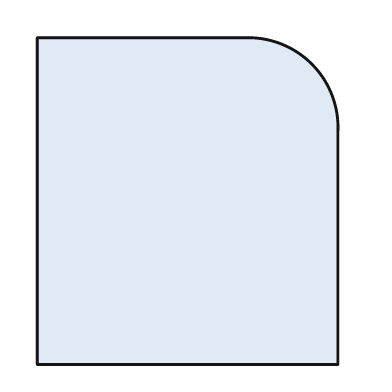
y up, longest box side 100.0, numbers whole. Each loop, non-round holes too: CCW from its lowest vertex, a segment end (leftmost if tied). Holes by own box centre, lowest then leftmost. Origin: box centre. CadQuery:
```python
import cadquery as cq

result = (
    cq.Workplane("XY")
    .moveTo(-46.0, -50.0)
    .lineTo(46.0, -50.0)
    .lineTo(46.0, 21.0)
    .threePointArc((38.0, 42.0), (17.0, 50.0))
    .lineTo(-46.0, 50.0)
    .close()
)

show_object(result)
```